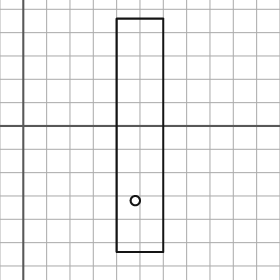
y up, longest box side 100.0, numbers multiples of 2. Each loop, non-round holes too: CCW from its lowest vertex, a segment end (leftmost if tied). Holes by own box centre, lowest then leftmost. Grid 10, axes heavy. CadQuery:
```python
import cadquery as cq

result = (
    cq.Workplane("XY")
    .moveTo(40.0, -54.0)
    .lineTo(60.0, -54.0)
    .lineTo(60.0, 46.0)
    .lineTo(40.0, 46.0)
    .close()
    .moveTo(48.0, -32.0)
    .circle(2.0)
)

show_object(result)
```